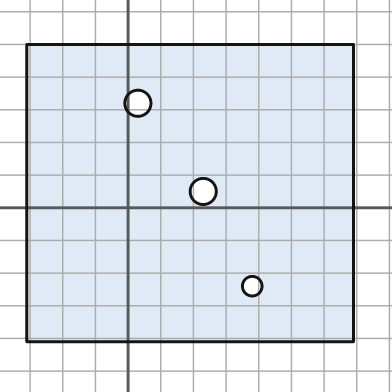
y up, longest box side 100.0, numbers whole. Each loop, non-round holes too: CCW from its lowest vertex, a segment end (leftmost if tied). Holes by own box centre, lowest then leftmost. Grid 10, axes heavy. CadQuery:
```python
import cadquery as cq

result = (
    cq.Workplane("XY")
    .moveTo(-31.0, -41.0)
    .lineTo(69.0, -41.0)
    .lineTo(69.0, 50.0)
    .lineTo(-31.0, 50.0)
    .close()
    .moveTo(38.0, -24.0)
    .circle(3.0)
    .moveTo(23.0, 5.0)
    .circle(4.0)
    .moveTo(3.0, 32.0)
    .circle(4.0)
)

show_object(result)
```